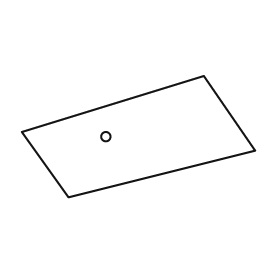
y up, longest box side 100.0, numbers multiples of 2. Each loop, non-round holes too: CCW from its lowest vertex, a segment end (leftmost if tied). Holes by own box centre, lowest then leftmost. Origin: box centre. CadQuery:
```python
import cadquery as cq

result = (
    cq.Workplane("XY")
    .moveTo(-30.0, -26.0)
    .lineTo(50.0, -6.0)
    .lineTo(28.0, 26.0)
    .lineTo(-50.0, 2.0)
    .close()
    .moveTo(-14.0, 0.0)
    .circle(2.0)
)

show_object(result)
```